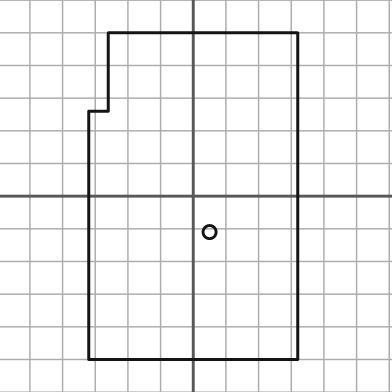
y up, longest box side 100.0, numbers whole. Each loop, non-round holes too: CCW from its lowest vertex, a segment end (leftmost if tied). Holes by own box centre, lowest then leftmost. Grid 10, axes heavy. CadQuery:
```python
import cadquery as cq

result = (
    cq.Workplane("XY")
    .moveTo(-32.0, -50.0)
    .lineTo(32.0, -50.0)
    .lineTo(32.0, 50.0)
    .lineTo(-26.0, 50.0)
    .lineTo(-26.0, 26.0)
    .lineTo(-32.0, 26.0)
    .close()
    .moveTo(5.0, -11.0)
    .circle(2.0)
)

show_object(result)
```